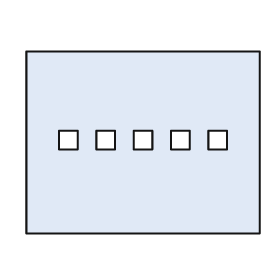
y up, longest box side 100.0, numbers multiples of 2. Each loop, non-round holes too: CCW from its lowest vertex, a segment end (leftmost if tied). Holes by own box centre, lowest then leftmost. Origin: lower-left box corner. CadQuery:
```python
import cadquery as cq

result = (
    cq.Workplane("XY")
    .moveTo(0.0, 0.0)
    .lineTo(100.0, 0.0)
    .lineTo(100.0, 78.0)
    .lineTo(0.0, 78.0)
    .close()
    .moveTo(14.0, 36.0)
    .lineTo(22.0, 36.0)
    .lineTo(22.0, 44.0)
    .lineTo(14.0, 44.0)
    .close()
    .moveTo(30.0, 36.0)
    .lineTo(38.0, 36.0)
    .lineTo(38.0, 44.0)
    .lineTo(30.0, 44.0)
    .close()
    .moveTo(46.0, 36.0)
    .lineTo(54.0, 36.0)
    .lineTo(54.0, 44.0)
    .lineTo(46.0, 44.0)
    .close()
    .moveTo(62.0, 36.0)
    .lineTo(70.0, 36.0)
    .lineTo(70.0, 44.0)
    .lineTo(62.0, 44.0)
    .close()
    .moveTo(78.0, 36.0)
    .lineTo(86.0, 36.0)
    .lineTo(86.0, 44.0)
    .lineTo(78.0, 44.0)
    .close()
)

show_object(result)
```